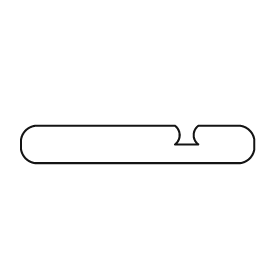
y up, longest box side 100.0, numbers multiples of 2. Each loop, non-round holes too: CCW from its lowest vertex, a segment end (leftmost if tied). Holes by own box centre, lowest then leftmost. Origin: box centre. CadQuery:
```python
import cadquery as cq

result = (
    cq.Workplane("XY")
    .moveTo(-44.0, -8.0)
    .lineTo(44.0, -8.0)
    .threePointArc((48.0, -6.0), (50.0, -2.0))
    .lineTo(50.0, 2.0)
    .threePointArc((48.0, 6.0), (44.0, 8.0))
    .lineTo(26.0, 8.0)
    .threePointArc((24.0, 4.0), (26.0, 0.0))
    .lineTo(16.0, 0.0)
    .threePointArc((18.0, 4.0), (16.0, 8.0))
    .lineTo(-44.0, 8.0)
    .threePointArc((-48.0, 6.0), (-50.0, 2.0))
    .lineTo(-50.0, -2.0)
    .threePointArc((-48.0, -6.0), (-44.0, -8.0))
    .close()
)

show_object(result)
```